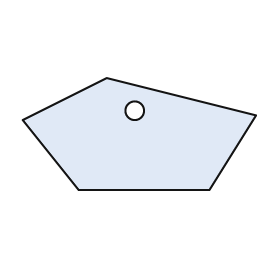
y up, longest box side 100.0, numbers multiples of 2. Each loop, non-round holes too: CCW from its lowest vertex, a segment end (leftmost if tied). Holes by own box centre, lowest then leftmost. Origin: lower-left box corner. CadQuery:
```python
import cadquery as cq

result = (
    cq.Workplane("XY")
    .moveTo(24.0, 0.0)
    .lineTo(80.0, 0.0)
    .lineTo(100.0, 32.0)
    .lineTo(36.0, 48.0)
    .lineTo(0.0, 30.0)
    .close()
    .moveTo(48.0, 34.0)
    .circle(4.0)
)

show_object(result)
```